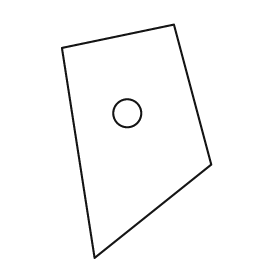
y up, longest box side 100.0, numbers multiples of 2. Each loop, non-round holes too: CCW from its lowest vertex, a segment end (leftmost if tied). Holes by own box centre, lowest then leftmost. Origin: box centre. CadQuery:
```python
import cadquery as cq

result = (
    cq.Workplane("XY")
    .moveTo(-18.0, -50.0)
    .lineTo(32.0, -10.0)
    .lineTo(16.0, 50.0)
    .lineTo(-32.0, 40.0)
    .close()
    .moveTo(-4.0, 12.0)
    .circle(6.0)
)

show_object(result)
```